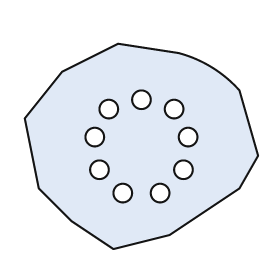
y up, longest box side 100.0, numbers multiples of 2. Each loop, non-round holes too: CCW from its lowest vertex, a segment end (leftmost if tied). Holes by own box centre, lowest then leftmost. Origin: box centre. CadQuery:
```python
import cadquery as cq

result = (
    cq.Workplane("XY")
    .moveTo(-12.0, -44.0)
    .lineTo(12.0, -38.0)
    .lineTo(42.0, -18.0)
    .lineTo(50.0, -4.0)
    .lineTo(42.0, 24.0)
    .threePointArc((30.0, 34.0), (16.0, 40.0))
    .lineTo(-10.0, 44.0)
    .lineTo(-34.0, 32.0)
    .lineTo(-50.0, 12.0)
    .lineTo(-44.0, -18.0)
    .lineTo(-30.0, -32.0)
    .close()
    .moveTo(-8.0, -20.0)
    .circle(4.0)
    .moveTo(8.0, -20.0)
    .circle(4.0)
    .moveTo(-18.0, -10.0)
    .circle(4.0)
    .moveTo(18.0, -10.0)
    .circle(4.0)
    .moveTo(-20.0, 4.0)
    .circle(4.0)
    .moveTo(20.0, 4.0)
    .circle(4.0)
    .moveTo(-14.0, 16.0)
    .circle(4.0)
    .moveTo(14.0, 16.0)
    .circle(4.0)
    .moveTo(0.0, 20.0)
    .circle(4.0)
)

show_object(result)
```